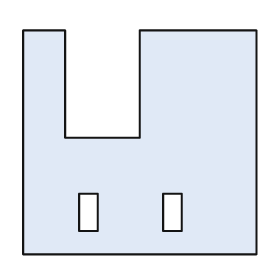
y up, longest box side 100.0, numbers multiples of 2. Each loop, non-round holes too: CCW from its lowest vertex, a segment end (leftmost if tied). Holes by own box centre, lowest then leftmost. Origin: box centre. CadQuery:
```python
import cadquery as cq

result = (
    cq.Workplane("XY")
    .moveTo(-50.0, -48.0)
    .lineTo(50.0, -48.0)
    .lineTo(50.0, 48.0)
    .lineTo(0.0, 48.0)
    .lineTo(0.0, 2.0)
    .lineTo(-32.0, 2.0)
    .lineTo(-32.0, 48.0)
    .lineTo(-50.0, 48.0)
    .close()
    .moveTo(-26.0, -38.0)
    .lineTo(-18.0, -38.0)
    .lineTo(-18.0, -22.0)
    .lineTo(-26.0, -22.0)
    .close()
    .moveTo(10.0, -38.0)
    .lineTo(18.0, -38.0)
    .lineTo(18.0, -22.0)
    .lineTo(10.0, -22.0)
    .close()
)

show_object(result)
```